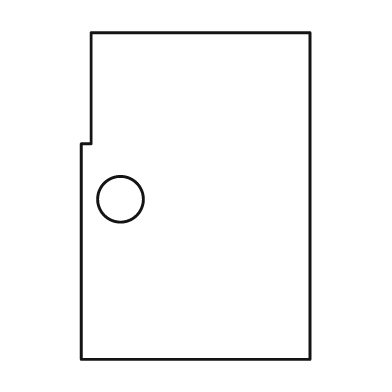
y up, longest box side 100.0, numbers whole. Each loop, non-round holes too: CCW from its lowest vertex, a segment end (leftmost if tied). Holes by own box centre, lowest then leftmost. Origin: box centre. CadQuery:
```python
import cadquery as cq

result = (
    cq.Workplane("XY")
    .moveTo(-35.0, -50.0)
    .lineTo(35.0, -50.0)
    .lineTo(35.0, 50.0)
    .lineTo(-32.0, 50.0)
    .lineTo(-32.0, 16.0)
    .lineTo(-35.0, 16.0)
    .close()
    .moveTo(-23.0, -1.0)
    .circle(7.0)
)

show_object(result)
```